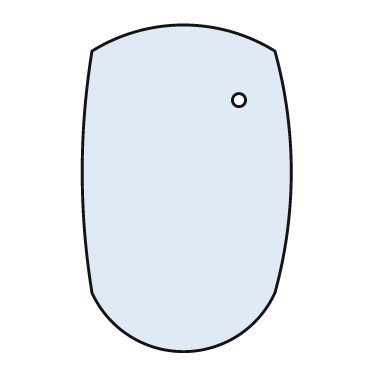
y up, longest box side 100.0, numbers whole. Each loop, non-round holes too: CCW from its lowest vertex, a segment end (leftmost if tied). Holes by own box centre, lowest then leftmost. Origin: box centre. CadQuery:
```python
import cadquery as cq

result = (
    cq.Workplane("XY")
    .moveTo(-29.0, -32.0)
    .threePointArc((-1.0, -50.0), (27.0, -32.0))
    .threePointArc((32.0, 5.0), (27.0, 42.0))
    .threePointArc((-1.0, 50.0), (-29.0, 42.0))
    .threePointArc((-32.0, 5.0), (-29.0, -32.0))
    .close()
    .moveTo(16.0, 27.0)
    .circle(2.0)
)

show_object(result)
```